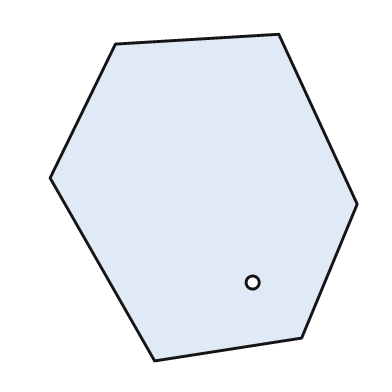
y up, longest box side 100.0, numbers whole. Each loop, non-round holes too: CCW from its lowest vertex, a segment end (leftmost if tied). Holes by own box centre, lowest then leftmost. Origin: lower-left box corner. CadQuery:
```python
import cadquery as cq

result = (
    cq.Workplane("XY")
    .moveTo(32.0, 0.0)
    .lineTo(77.0, 7.0)
    .lineTo(94.0, 48.0)
    .lineTo(70.0, 100.0)
    .lineTo(20.0, 97.0)
    .lineTo(0.0, 56.0)
    .close()
    .moveTo(62.0, 24.0)
    .circle(2.0)
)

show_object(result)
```